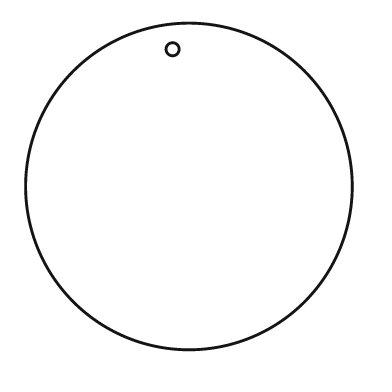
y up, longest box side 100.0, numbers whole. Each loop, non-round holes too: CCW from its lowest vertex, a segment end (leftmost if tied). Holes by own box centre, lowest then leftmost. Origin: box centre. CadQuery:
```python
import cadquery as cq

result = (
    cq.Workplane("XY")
    .moveTo(0.0, 0.0)
    .circle(50.0)
    .moveTo(-5.0, 42.0)
    .circle(2.0)
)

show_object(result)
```